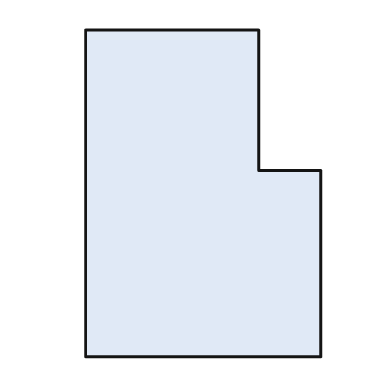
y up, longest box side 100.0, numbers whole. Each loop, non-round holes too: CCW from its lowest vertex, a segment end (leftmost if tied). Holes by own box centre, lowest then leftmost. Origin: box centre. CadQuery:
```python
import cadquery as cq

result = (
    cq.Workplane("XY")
    .moveTo(-36.0, -50.0)
    .lineTo(36.0, -50.0)
    .lineTo(36.0, 7.0)
    .lineTo(17.0, 7.0)
    .lineTo(17.0, 50.0)
    .lineTo(-36.0, 50.0)
    .close()
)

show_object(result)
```